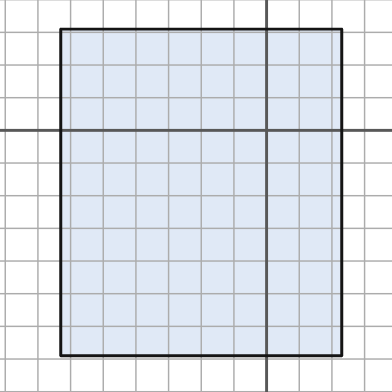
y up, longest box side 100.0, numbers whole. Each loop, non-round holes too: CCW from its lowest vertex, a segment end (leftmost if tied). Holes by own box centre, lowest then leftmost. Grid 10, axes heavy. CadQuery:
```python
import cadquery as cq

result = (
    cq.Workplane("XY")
    .moveTo(-63.0, -69.0)
    .lineTo(23.0, -69.0)
    .lineTo(23.0, 31.0)
    .lineTo(-63.0, 31.0)
    .close()
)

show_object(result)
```